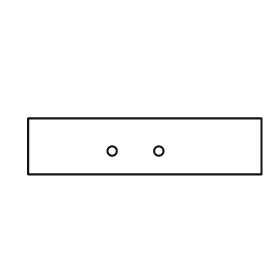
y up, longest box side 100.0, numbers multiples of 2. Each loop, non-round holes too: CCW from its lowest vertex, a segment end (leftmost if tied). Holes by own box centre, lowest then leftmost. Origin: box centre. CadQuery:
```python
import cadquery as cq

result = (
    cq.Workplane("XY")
    .moveTo(-50.0, -12.0)
    .lineTo(50.0, -12.0)
    .lineTo(50.0, 12.0)
    .lineTo(-50.0, 12.0)
    .close()
    .moveTo(-14.0, -2.0)
    .circle(2.0)
    .moveTo(6.0, -2.0)
    .circle(2.0)
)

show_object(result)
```